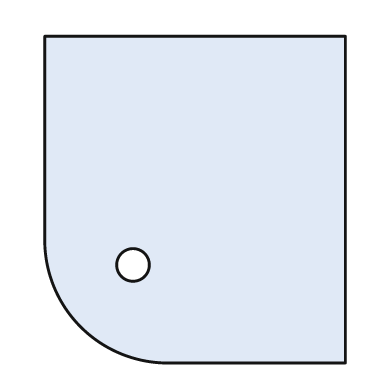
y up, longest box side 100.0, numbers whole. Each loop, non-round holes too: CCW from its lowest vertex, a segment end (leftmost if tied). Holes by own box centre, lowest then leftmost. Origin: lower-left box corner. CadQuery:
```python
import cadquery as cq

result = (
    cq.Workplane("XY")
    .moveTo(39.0, 0.0)
    .lineTo(92.0, 0.0)
    .lineTo(92.0, 100.0)
    .lineTo(0.0, 100.0)
    .lineTo(0.0, 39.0)
    .threePointArc((11.0, 11.0), (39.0, 0.0))
    .close()
    .moveTo(27.0, 30.0)
    .circle(5.0)
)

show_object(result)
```